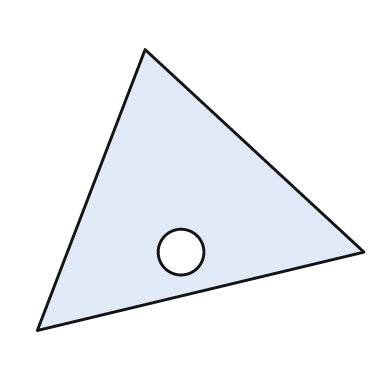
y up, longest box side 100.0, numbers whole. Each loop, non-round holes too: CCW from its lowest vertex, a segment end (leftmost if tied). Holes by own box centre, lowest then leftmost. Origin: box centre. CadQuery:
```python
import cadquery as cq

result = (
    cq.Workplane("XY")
    .moveTo(-50.0, -43.0)
    .lineTo(50.0, -19.0)
    .lineTo(-17.0, 43.0)
    .close()
    .moveTo(-6.0, -19.0)
    .circle(7.0)
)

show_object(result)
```